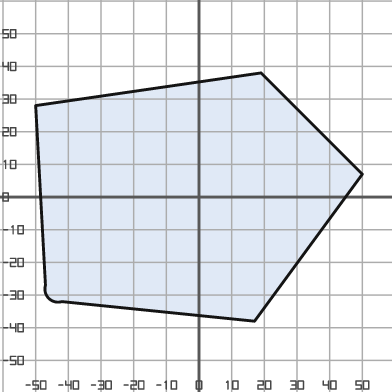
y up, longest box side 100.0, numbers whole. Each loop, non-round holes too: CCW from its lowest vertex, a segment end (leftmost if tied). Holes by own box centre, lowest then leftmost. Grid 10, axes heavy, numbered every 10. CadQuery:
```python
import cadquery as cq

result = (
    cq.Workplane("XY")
    .moveTo(17.0, -38.0)
    .lineTo(50.0, 7.0)
    .lineTo(19.0, 38.0)
    .lineTo(-50.0, 28.0)
    .lineTo(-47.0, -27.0)
    .threePointArc((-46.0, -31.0), (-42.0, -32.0))
    .close()
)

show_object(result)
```